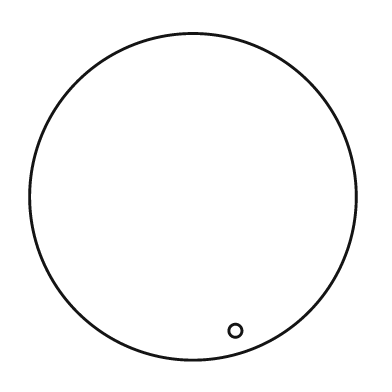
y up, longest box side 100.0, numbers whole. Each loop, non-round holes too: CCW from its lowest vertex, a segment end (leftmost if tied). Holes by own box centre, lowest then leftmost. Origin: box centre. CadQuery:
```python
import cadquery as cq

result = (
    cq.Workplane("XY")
    .moveTo(0.0, 0.0)
    .circle(50.0)
    .moveTo(13.0, -41.0)
    .circle(2.0)
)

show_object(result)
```